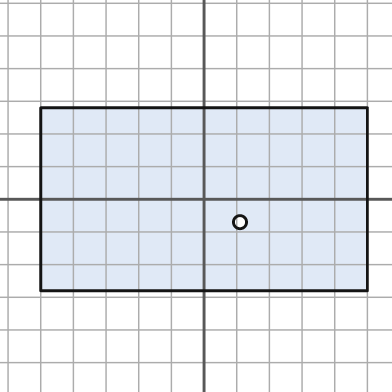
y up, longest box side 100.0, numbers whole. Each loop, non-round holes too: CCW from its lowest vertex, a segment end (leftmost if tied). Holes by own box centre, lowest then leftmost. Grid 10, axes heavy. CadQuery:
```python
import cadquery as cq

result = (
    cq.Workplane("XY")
    .moveTo(-50.0, -28.0)
    .lineTo(50.0, -28.0)
    .lineTo(50.0, 28.0)
    .lineTo(-50.0, 28.0)
    .close()
    .moveTo(11.0, -7.0)
    .circle(2.0)
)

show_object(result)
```